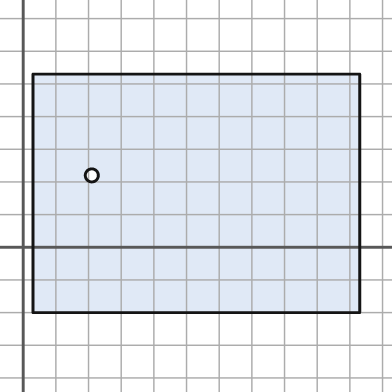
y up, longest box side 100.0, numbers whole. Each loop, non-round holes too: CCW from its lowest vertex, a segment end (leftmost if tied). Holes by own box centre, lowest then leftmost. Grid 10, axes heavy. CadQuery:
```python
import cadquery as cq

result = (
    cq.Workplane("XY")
    .moveTo(3.0, -20.0)
    .lineTo(103.0, -20.0)
    .lineTo(103.0, 53.0)
    .lineTo(3.0, 53.0)
    .close()
    .moveTo(21.0, 22.0)
    .circle(2.0)
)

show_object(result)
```